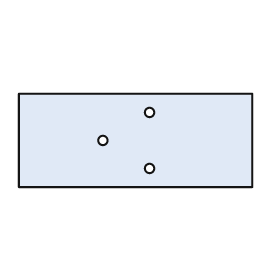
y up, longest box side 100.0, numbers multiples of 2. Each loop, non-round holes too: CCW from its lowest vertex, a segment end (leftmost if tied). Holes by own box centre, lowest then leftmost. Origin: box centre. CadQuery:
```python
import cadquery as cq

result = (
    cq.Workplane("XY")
    .moveTo(-50.0, -20.0)
    .lineTo(50.0, -20.0)
    .lineTo(50.0, 20.0)
    .lineTo(-50.0, 20.0)
    .close()
    .moveTo(6.0, -12.0)
    .circle(2.0)
    .moveTo(-14.0, 0.0)
    .circle(2.0)
    .moveTo(6.0, 12.0)
    .circle(2.0)
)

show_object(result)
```